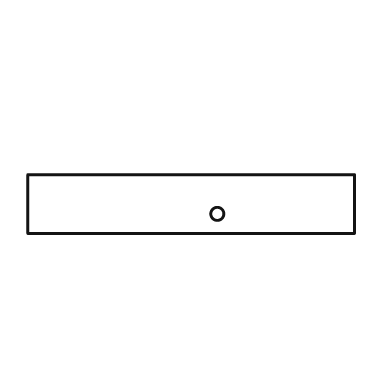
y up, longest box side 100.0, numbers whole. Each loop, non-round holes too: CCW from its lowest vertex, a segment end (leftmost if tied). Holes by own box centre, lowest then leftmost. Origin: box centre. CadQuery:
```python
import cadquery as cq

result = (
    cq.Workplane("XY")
    .moveTo(-50.0, -9.0)
    .lineTo(50.0, -9.0)
    .lineTo(50.0, 9.0)
    .lineTo(-50.0, 9.0)
    .close()
    .moveTo(8.0, -3.0)
    .circle(2.0)
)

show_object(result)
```